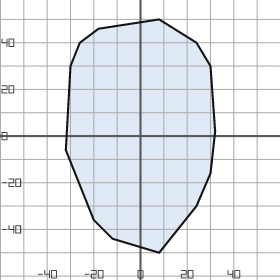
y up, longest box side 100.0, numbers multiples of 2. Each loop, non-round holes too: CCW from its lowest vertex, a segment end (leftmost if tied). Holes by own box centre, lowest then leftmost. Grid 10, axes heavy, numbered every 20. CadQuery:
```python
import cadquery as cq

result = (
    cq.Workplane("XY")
    .moveTo(8.0, -50.0)
    .lineTo(24.0, -30.0)
    .lineTo(30.0, -16.0)
    .lineTo(32.0, 2.0)
    .lineTo(30.0, 30.0)
    .lineTo(24.0, 40.0)
    .lineTo(8.0, 50.0)
    .lineTo(-18.0, 46.0)
    .lineTo(-26.0, 40.0)
    .lineTo(-30.0, 30.0)
    .lineTo(-32.0, -6.0)
    .lineTo(-20.0, -36.0)
    .lineTo(-12.0, -44.0)
    .close()
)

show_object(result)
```